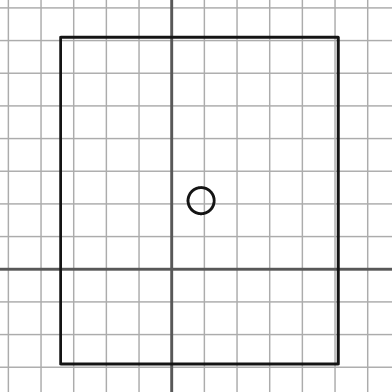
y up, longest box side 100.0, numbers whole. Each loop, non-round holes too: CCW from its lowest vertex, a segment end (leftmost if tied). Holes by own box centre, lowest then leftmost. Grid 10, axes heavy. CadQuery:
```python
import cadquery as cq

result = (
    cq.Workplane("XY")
    .moveTo(-34.0, -29.0)
    .lineTo(51.0, -29.0)
    .lineTo(51.0, 71.0)
    .lineTo(-34.0, 71.0)
    .close()
    .moveTo(9.0, 21.0)
    .circle(4.0)
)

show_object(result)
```